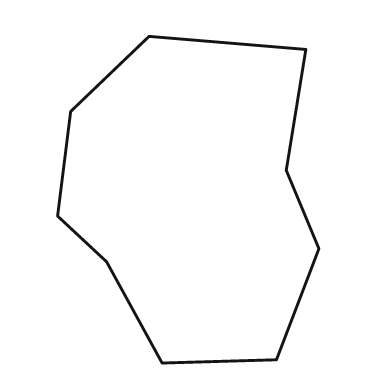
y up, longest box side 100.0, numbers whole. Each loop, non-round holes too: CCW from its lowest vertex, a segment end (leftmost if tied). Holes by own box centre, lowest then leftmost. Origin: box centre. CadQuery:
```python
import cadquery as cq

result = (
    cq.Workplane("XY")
    .moveTo(-8.0, -50.0)
    .lineTo(27.0, -49.0)
    .lineTo(40.0, -15.0)
    .lineTo(30.0, 9.0)
    .lineTo(36.0, 46.0)
    .lineTo(-12.0, 50.0)
    .lineTo(-36.0, 27.0)
    .lineTo(-40.0, -5.0)
    .lineTo(-25.0, -19.0)
    .close()
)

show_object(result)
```